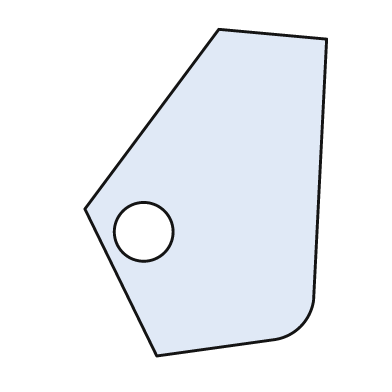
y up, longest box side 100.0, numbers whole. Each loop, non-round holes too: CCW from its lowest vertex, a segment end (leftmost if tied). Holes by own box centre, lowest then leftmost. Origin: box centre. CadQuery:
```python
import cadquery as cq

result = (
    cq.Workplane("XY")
    .moveTo(-15.0, -50.0)
    .lineTo(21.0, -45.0)
    .threePointArc((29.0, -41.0), (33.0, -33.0))
    .lineTo(37.0, 47.0)
    .lineTo(4.0, 50.0)
    .lineTo(-37.0, -5.0)
    .close()
    .moveTo(-19.0, -12.0)
    .circle(9.0)
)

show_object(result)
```